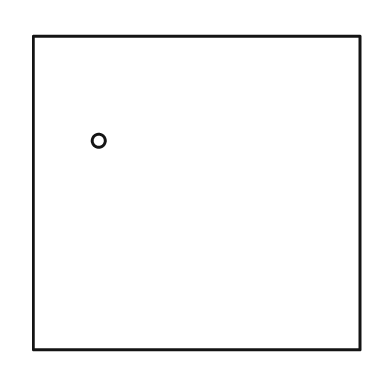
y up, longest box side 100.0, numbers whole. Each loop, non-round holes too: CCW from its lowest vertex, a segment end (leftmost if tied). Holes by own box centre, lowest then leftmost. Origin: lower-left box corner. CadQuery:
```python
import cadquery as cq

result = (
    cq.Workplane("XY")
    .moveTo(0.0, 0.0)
    .lineTo(100.0, 0.0)
    .lineTo(100.0, 96.0)
    .lineTo(0.0, 96.0)
    .close()
    .moveTo(20.0, 64.0)
    .circle(2.0)
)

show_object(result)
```